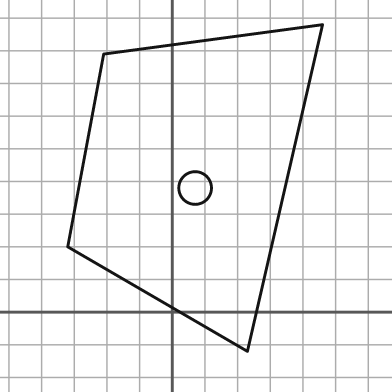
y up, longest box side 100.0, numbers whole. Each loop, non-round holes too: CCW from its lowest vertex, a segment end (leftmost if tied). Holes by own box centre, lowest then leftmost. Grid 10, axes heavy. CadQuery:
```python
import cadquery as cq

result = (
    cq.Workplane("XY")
    .moveTo(23.0, -12.0)
    .lineTo(46.0, 88.0)
    .lineTo(-21.0, 79.0)
    .lineTo(-32.0, 20.0)
    .close()
    .moveTo(7.0, 38.0)
    .circle(5.0)
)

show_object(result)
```